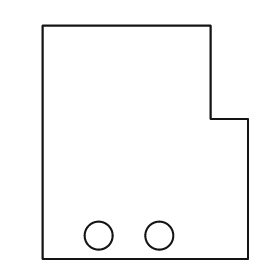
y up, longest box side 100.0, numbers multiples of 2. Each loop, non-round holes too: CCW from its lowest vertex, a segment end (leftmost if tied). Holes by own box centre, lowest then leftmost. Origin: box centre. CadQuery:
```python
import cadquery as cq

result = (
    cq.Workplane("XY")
    .moveTo(-44.0, -50.0)
    .lineTo(44.0, -50.0)
    .lineTo(44.0, 10.0)
    .lineTo(28.0, 10.0)
    .lineTo(28.0, 50.0)
    .lineTo(-44.0, 50.0)
    .close()
    .moveTo(-20.0, -40.0)
    .circle(6.0)
    .moveTo(6.0, -40.0)
    .circle(6.0)
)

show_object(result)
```